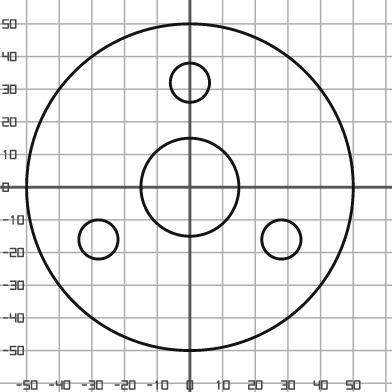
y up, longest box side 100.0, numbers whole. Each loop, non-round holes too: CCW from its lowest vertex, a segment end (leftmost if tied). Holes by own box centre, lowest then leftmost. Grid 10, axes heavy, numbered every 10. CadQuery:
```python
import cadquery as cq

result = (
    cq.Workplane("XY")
    .moveTo(0.0, 0.0)
    .circle(50.0)
    .moveTo(-28.0, -16.0)
    .circle(6.0)
    .moveTo(28.0, -16.0)
    .circle(6.0)
    .moveTo(0.0, 0.0)
    .circle(15.0)
    .moveTo(0.0, 32.0)
    .circle(6.0)
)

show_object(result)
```